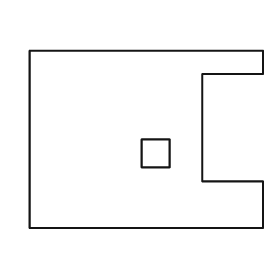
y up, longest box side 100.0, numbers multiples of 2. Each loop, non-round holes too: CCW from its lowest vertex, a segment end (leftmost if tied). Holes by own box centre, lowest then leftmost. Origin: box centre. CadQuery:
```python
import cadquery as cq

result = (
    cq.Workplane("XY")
    .moveTo(-50.0, -38.0)
    .lineTo(50.0, -38.0)
    .lineTo(50.0, -18.0)
    .lineTo(24.0, -18.0)
    .lineTo(24.0, 28.0)
    .lineTo(50.0, 28.0)
    .lineTo(50.0, 38.0)
    .lineTo(-50.0, 38.0)
    .close()
    .moveTo(-2.0, -12.0)
    .lineTo(10.0, -12.0)
    .lineTo(10.0, 0.0)
    .lineTo(-2.0, 0.0)
    .close()
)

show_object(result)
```